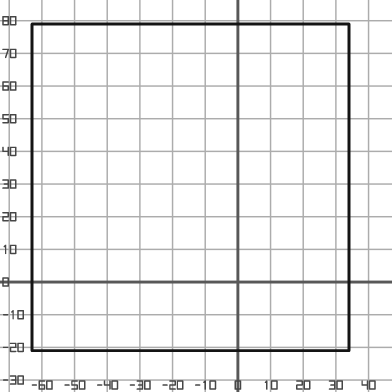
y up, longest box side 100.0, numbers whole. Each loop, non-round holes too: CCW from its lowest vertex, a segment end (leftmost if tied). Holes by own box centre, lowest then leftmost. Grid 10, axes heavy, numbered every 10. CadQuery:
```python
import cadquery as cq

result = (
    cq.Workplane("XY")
    .moveTo(-63.0, -21.0)
    .lineTo(34.0, -21.0)
    .lineTo(34.0, 79.0)
    .lineTo(-63.0, 79.0)
    .close()
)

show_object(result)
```